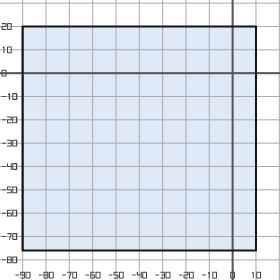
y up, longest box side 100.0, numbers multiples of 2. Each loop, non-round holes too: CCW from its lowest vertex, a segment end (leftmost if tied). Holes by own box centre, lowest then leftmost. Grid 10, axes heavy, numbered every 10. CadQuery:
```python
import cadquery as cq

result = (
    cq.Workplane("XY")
    .moveTo(-90.0, -76.0)
    .lineTo(10.0, -76.0)
    .lineTo(10.0, 20.0)
    .lineTo(-90.0, 20.0)
    .close()
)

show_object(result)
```